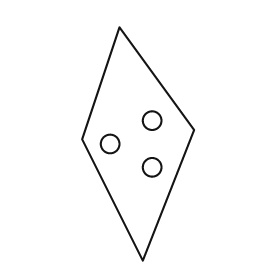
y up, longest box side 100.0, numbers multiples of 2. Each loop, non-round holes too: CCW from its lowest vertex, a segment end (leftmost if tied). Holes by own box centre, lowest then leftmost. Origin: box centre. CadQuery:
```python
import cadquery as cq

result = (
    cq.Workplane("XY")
    .moveTo(2.0, -50.0)
    .lineTo(24.0, 6.0)
    .lineTo(-8.0, 50.0)
    .lineTo(-24.0, 2.0)
    .close()
    .moveTo(6.0, -10.0)
    .circle(4.0)
    .moveTo(-12.0, 0.0)
    .circle(4.0)
    .moveTo(6.0, 10.0)
    .circle(4.0)
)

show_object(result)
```